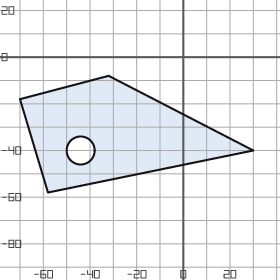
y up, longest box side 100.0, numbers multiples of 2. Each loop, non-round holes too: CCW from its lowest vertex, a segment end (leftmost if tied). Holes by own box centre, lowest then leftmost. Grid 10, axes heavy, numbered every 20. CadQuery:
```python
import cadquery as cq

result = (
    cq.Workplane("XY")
    .moveTo(-58.0, -58.0)
    .lineTo(30.0, -40.0)
    .lineTo(-32.0, -8.0)
    .lineTo(-70.0, -18.0)
    .close()
    .moveTo(-44.0, -40.0)
    .circle(6.0)
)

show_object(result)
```